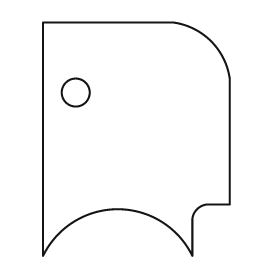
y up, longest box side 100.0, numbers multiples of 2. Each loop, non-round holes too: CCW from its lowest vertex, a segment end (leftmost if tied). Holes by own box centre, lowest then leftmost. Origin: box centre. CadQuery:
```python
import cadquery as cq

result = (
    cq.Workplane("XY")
    .moveTo(-40.0, -50.0)
    .threePointArc((-8.0, -30.0), (24.0, -50.0))
    .lineTo(24.0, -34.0)
    .threePointArc((26.0, -30.0), (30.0, -28.0))
    .lineTo(40.0, -28.0)
    .lineTo(40.0, 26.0)
    .threePointArc((32.0, 42.0), (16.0, 50.0))
    .lineTo(-40.0, 50.0)
    .close()
    .moveTo(-26.0, 20.0)
    .circle(6.0)
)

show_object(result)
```